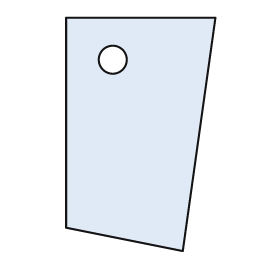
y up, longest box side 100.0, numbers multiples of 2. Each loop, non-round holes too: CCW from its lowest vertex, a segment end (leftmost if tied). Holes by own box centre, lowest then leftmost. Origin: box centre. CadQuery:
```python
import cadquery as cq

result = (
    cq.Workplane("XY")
    .moveTo(18.0, -50.0)
    .lineTo(32.0, 50.0)
    .lineTo(-32.0, 50.0)
    .lineTo(-32.0, -40.0)
    .close()
    .moveTo(-12.0, 32.0)
    .circle(6.0)
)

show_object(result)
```